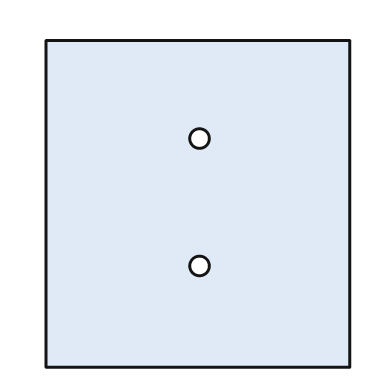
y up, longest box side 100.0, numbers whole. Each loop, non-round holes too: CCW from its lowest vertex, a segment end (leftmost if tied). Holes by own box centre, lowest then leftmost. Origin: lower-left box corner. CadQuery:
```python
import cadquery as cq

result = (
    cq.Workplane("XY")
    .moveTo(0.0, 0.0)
    .lineTo(93.0, 0.0)
    .lineTo(93.0, 100.0)
    .lineTo(0.0, 100.0)
    .close()
    .moveTo(47.0, 31.0)
    .circle(3.0)
    .moveTo(47.0, 70.0)
    .circle(3.0)
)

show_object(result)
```